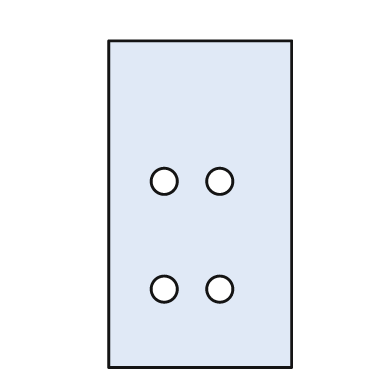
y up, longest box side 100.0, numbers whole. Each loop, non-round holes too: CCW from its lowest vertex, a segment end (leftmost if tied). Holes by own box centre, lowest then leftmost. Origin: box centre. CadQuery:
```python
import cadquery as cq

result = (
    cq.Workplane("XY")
    .moveTo(-28.0, -50.0)
    .lineTo(28.0, -50.0)
    .lineTo(28.0, 50.0)
    .lineTo(-28.0, 50.0)
    .close()
    .moveTo(-11.0, -26.0)
    .circle(4.0)
    .moveTo(6.0, -26.0)
    .circle(4.0)
    .moveTo(-11.0, 7.0)
    .circle(4.0)
    .moveTo(6.0, 7.0)
    .circle(4.0)
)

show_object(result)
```